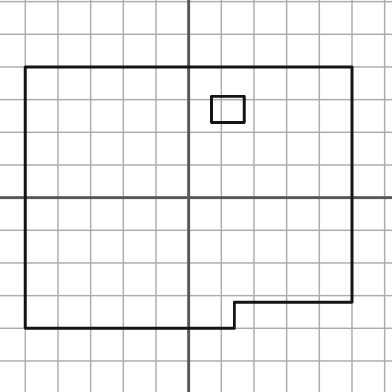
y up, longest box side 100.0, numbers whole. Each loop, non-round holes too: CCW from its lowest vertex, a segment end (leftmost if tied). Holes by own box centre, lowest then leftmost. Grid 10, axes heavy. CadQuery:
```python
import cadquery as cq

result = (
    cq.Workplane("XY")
    .moveTo(-50.0, -40.0)
    .lineTo(14.0, -40.0)
    .lineTo(14.0, -32.0)
    .lineTo(50.0, -32.0)
    .lineTo(50.0, 40.0)
    .lineTo(-50.0, 40.0)
    .close()
    .moveTo(7.0, 23.0)
    .lineTo(17.0, 23.0)
    .lineTo(17.0, 31.0)
    .lineTo(7.0, 31.0)
    .close()
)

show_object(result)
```